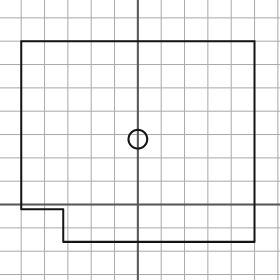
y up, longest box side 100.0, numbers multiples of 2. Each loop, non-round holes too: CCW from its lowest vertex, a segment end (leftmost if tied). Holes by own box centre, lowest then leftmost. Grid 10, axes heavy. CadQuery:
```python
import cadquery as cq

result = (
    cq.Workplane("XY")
    .moveTo(-32.0, -16.0)
    .lineTo(50.0, -16.0)
    .lineTo(50.0, 70.0)
    .lineTo(-50.0, 70.0)
    .lineTo(-50.0, -2.0)
    .lineTo(-32.0, -2.0)
    .close()
    .moveTo(0.0, 28.0)
    .circle(4.0)
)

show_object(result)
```